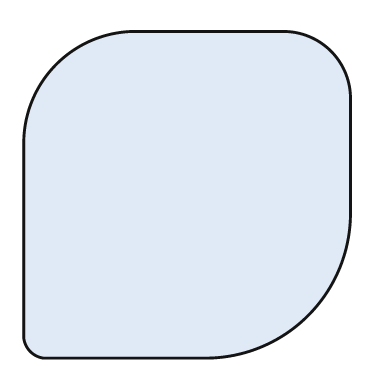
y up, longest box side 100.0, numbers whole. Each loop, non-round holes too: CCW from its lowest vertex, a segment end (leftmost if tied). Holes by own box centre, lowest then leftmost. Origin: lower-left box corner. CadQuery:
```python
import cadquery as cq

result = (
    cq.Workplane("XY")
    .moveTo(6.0, 0.0)
    .lineTo(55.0, 0.0)
    .threePointArc((87.0, 13.0), (100.0, 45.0))
    .lineTo(100.0, 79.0)
    .threePointArc((94.0, 94.0), (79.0, 100.0))
    .lineTo(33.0, 100.0)
    .threePointArc((10.0, 90.0), (0.0, 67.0))
    .lineTo(0.0, 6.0)
    .threePointArc((2.0, 2.0), (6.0, 0.0))
    .close()
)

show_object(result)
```